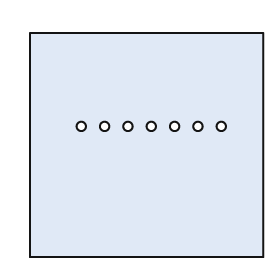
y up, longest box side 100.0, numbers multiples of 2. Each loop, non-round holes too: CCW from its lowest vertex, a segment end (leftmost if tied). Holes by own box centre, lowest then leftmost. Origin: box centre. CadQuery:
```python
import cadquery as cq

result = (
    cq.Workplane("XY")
    .moveTo(-50.0, -48.0)
    .lineTo(50.0, -48.0)
    .lineTo(50.0, 48.0)
    .lineTo(-50.0, 48.0)
    .close()
    .moveTo(-28.0, 8.0)
    .circle(2.0)
    .moveTo(-18.0, 8.0)
    .circle(2.0)
    .moveTo(-8.0, 8.0)
    .circle(2.0)
    .moveTo(2.0, 8.0)
    .circle(2.0)
    .moveTo(12.0, 8.0)
    .circle(2.0)
    .moveTo(22.0, 8.0)
    .circle(2.0)
    .moveTo(32.0, 8.0)
    .circle(2.0)
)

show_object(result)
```